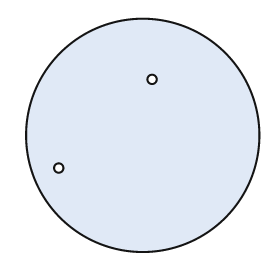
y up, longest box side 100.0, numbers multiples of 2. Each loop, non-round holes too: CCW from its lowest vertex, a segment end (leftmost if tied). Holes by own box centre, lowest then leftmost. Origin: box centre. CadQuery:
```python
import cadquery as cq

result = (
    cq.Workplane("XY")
    .moveTo(0.0, 0.0)
    .circle(50.0)
    .moveTo(-36.0, -14.0)
    .circle(2.0)
    .moveTo(4.0, 24.0)
    .circle(2.0)
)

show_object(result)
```